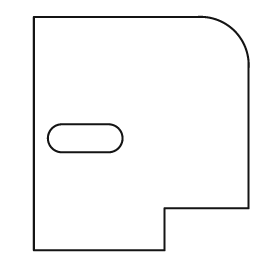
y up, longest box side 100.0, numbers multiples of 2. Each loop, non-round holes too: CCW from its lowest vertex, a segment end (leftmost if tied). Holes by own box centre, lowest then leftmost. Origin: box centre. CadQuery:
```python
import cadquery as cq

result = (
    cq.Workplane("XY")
    .moveTo(-46.0, -50.0)
    .lineTo(10.0, -50.0)
    .lineTo(10.0, -32.0)
    .lineTo(46.0, -32.0)
    .lineTo(46.0, 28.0)
    .threePointArc((40.0, 44.0), (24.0, 50.0))
    .lineTo(-46.0, 50.0)
    .close()
    .moveTo(-34.0, -8.0)
    .lineTo(-14.0, -8.0)
    .threePointArc((-8.0, -2.0), (-14.0, 4.0))
    .lineTo(-34.0, 4.0)
    .threePointArc((-40.0, -2.0), (-34.0, -8.0))
    .close()
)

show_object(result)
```